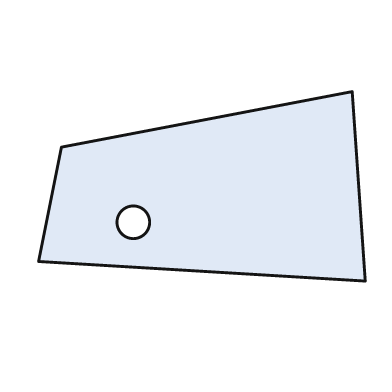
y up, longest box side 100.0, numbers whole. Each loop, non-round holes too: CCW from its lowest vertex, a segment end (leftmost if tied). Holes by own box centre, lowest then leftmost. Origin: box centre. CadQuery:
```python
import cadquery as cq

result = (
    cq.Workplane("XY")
    .moveTo(50.0, -29.0)
    .lineTo(46.0, 29.0)
    .lineTo(-43.0, 12.0)
    .lineTo(-50.0, -23.0)
    .close()
    .moveTo(-21.0, -11.0)
    .circle(5.0)
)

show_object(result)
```